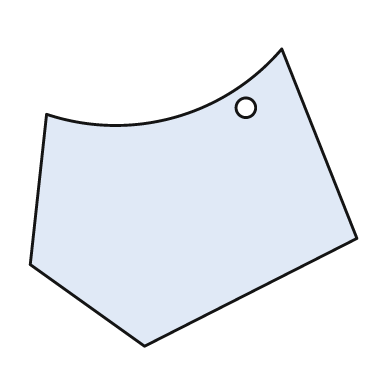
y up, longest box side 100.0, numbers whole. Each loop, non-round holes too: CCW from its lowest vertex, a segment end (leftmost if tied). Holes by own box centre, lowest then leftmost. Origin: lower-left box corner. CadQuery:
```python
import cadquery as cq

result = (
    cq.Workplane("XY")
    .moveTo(35.0, 0.0)
    .lineTo(100.0, 33.0)
    .lineTo(77.0, 91.0)
    .threePointArc((44.0, 70.0), (5.0, 71.0))
    .lineTo(0.0, 25.0)
    .close()
    .moveTo(66.0, 73.0)
    .circle(3.0)
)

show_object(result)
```